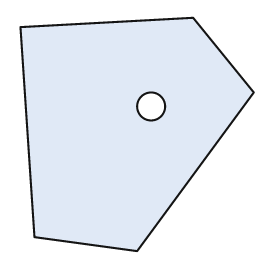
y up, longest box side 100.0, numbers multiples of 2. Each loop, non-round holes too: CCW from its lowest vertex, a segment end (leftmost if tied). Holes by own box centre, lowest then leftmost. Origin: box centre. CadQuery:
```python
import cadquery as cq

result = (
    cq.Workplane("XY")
    .moveTo(0.0, -50.0)
    .lineTo(50.0, 18.0)
    .lineTo(24.0, 50.0)
    .lineTo(-50.0, 46.0)
    .lineTo(-44.0, -44.0)
    .close()
    .moveTo(6.0, 12.0)
    .circle(6.0)
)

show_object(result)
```